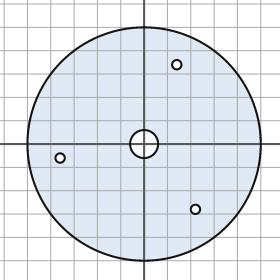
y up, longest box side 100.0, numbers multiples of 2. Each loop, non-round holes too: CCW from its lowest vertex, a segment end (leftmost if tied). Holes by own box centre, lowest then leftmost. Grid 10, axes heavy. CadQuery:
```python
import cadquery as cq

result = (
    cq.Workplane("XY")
    .moveTo(0.0, 0.0)
    .circle(50.0)
    .moveTo(22.0, -28.0)
    .circle(2.0)
    .moveTo(-36.0, -6.0)
    .circle(2.0)
    .moveTo(0.0, 0.0)
    .circle(6.0)
    .moveTo(14.0, 34.0)
    .circle(2.0)
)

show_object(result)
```